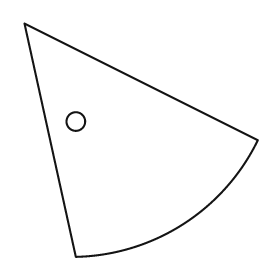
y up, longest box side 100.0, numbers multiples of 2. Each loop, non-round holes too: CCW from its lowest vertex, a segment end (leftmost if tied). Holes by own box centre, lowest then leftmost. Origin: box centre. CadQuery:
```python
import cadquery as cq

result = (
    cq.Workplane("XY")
    .moveTo(-28.0, -50.0)
    .threePointArc((18.0, -36.0), (50.0, 0.0))
    .lineTo(-50.0, 50.0)
    .close()
    .moveTo(-28.0, 8.0)
    .circle(4.0)
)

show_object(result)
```